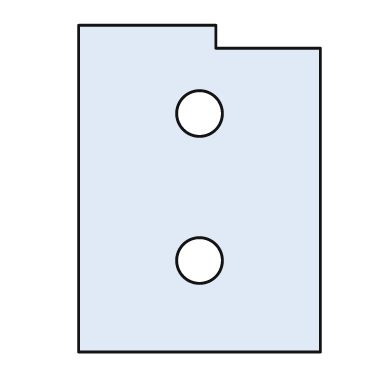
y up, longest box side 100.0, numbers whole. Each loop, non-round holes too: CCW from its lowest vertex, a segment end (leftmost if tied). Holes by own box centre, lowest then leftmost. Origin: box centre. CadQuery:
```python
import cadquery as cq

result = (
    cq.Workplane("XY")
    .moveTo(-37.0, -50.0)
    .lineTo(37.0, -50.0)
    .lineTo(37.0, 43.0)
    .lineTo(5.0, 43.0)
    .lineTo(5.0, 50.0)
    .lineTo(-37.0, 50.0)
    .close()
    .moveTo(0.0, -22.0)
    .circle(7.0)
    .moveTo(0.0, 23.0)
    .circle(7.0)
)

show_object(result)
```